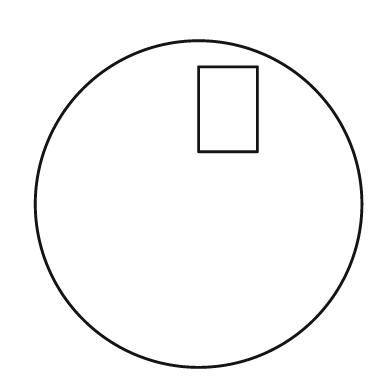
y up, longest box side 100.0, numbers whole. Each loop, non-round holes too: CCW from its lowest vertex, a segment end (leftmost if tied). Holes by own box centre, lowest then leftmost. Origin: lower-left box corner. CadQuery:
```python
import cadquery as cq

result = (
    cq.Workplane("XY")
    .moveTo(50.0, 50.0)
    .circle(50.0)
    .moveTo(50.0, 66.0)
    .lineTo(68.0, 66.0)
    .lineTo(68.0, 92.0)
    .lineTo(50.0, 92.0)
    .close()
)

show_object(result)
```